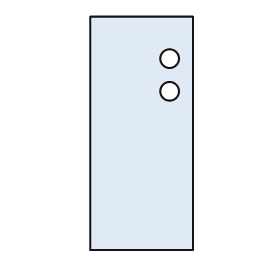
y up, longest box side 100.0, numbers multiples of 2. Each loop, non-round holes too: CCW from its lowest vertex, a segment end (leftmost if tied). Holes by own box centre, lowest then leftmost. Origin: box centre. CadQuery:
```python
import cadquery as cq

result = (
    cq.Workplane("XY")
    .moveTo(-22.0, -50.0)
    .lineTo(22.0, -50.0)
    .lineTo(22.0, 50.0)
    .lineTo(-22.0, 50.0)
    .close()
    .moveTo(12.0, 18.0)
    .circle(4.0)
    .moveTo(12.0, 32.0)
    .circle(4.0)
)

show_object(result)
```